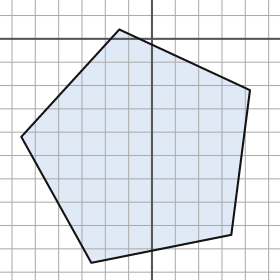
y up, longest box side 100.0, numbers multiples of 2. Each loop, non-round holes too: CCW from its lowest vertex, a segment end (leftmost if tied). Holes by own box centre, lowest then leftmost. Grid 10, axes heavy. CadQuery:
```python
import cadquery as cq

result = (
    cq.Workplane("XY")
    .moveTo(-26.0, -96.0)
    .lineTo(34.0, -84.0)
    .lineTo(42.0, -22.0)
    .lineTo(-14.0, 4.0)
    .lineTo(-56.0, -42.0)
    .close()
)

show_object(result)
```